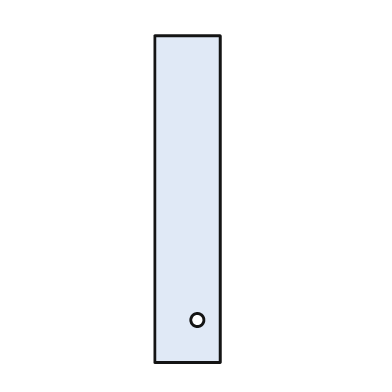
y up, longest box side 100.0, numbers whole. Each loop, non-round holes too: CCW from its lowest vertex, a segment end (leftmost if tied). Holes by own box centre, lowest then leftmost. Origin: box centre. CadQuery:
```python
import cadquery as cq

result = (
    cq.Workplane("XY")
    .moveTo(-10.0, -50.0)
    .lineTo(10.0, -50.0)
    .lineTo(10.0, 50.0)
    .lineTo(-10.0, 50.0)
    .close()
    .moveTo(3.0, -37.0)
    .circle(2.0)
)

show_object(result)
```